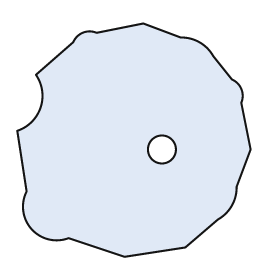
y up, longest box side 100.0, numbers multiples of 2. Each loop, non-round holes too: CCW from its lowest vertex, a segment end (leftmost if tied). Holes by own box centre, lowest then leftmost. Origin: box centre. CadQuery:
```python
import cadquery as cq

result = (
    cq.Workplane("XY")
    .moveTo(-4.0, -50.0)
    .lineTo(22.0, -46.0)
    .lineTo(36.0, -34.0)
    .threePointArc((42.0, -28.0), (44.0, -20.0))
    .lineTo(50.0, -4.0)
    .lineTo(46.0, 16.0)
    .threePointArc((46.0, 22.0), (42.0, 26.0))
    .lineTo(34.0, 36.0)
    .threePointArc((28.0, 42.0), (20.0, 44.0))
    .lineTo(4.0, 50.0)
    .lineTo(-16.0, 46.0)
    .threePointArc((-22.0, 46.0), (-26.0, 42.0))
    .lineTo(-42.0, 28.0)
    .threePointArc((-40.0, 14.0), (-50.0, 4.0))
    .lineTo(-46.0, -22.0)
    .threePointArc((-44.0, -38.0), (-28.0, -42.0))
    .close()
    .moveTo(12.0, -4.0)
    .circle(6.0)
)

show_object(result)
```